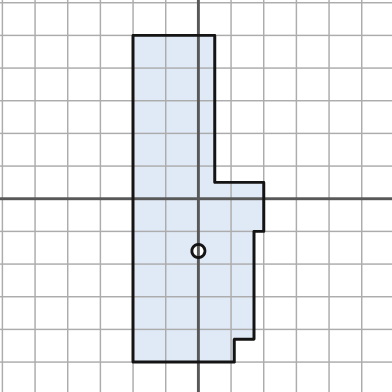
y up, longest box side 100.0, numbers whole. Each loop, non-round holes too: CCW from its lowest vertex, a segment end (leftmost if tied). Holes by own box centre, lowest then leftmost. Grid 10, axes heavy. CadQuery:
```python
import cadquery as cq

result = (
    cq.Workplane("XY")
    .moveTo(-20.0, -50.0)
    .lineTo(11.0, -50.0)
    .lineTo(11.0, -43.0)
    .lineTo(17.0, -43.0)
    .lineTo(17.0, -10.0)
    .lineTo(20.0, -10.0)
    .lineTo(20.0, 5.0)
    .lineTo(5.0, 5.0)
    .lineTo(5.0, 50.0)
    .lineTo(-20.0, 50.0)
    .close()
    .moveTo(0.0, -16.0)
    .circle(2.0)
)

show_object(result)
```